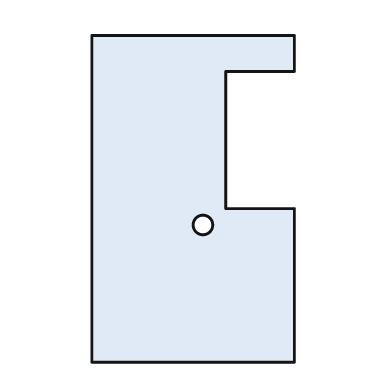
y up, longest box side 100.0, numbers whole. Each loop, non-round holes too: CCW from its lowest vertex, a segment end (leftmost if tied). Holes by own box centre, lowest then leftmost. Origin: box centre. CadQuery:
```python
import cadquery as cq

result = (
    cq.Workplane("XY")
    .moveTo(-31.0, -50.0)
    .lineTo(31.0, -50.0)
    .lineTo(31.0, -3.0)
    .lineTo(10.0, -3.0)
    .lineTo(10.0, 39.0)
    .lineTo(31.0, 39.0)
    .lineTo(31.0, 50.0)
    .lineTo(-31.0, 50.0)
    .close()
    .moveTo(3.0, -8.0)
    .circle(3.0)
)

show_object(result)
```